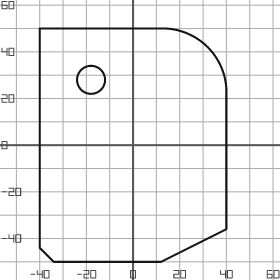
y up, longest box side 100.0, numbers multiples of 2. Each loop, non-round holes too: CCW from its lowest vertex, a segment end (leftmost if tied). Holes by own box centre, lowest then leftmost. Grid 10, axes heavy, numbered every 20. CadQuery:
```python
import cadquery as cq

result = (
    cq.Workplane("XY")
    .moveTo(-34.0, -50.0)
    .lineTo(12.0, -50.0)
    .lineTo(40.0, -36.0)
    .lineTo(40.0, 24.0)
    .threePointArc((32.0, 42.0), (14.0, 50.0))
    .lineTo(-40.0, 50.0)
    .lineTo(-40.0, -44.0)
    .close()
    .moveTo(-18.0, 28.0)
    .circle(6.0)
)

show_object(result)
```